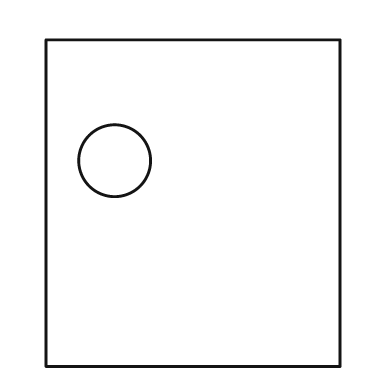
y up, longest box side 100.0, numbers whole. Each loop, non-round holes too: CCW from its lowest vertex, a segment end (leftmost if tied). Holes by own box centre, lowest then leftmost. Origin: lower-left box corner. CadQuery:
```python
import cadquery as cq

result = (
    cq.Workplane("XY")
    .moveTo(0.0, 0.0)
    .lineTo(90.0, 0.0)
    .lineTo(90.0, 100.0)
    .lineTo(0.0, 100.0)
    .close()
    .moveTo(21.0, 63.0)
    .circle(11.0)
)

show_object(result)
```